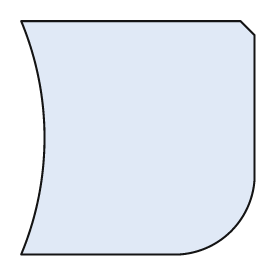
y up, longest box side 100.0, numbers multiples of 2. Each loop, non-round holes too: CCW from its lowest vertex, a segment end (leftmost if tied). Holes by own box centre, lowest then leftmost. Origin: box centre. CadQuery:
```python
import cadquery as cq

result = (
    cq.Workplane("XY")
    .moveTo(-50.0, -50.0)
    .lineTo(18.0, -50.0)
    .threePointArc((40.0, -40.0), (50.0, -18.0))
    .lineTo(50.0, 44.0)
    .lineTo(44.0, 50.0)
    .lineTo(-50.0, 50.0)
    .threePointArc((-40.0, 0.0), (-50.0, -50.0))
    .close()
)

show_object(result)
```